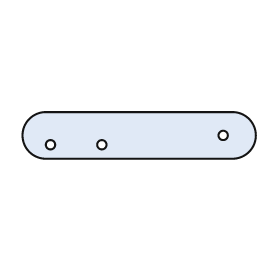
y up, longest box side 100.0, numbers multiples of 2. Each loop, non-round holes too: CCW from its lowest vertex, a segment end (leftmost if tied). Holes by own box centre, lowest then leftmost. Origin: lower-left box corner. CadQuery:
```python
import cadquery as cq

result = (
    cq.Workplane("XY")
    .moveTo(10.0, 0.0)
    .lineTo(90.0, 0.0)
    .threePointArc((100.0, 10.0), (90.0, 20.0))
    .lineTo(10.0, 20.0)
    .threePointArc((0.0, 10.0), (10.0, 0.0))
    .close()
    .moveTo(12.0, 6.0)
    .circle(2.0)
    .moveTo(34.0, 6.0)
    .circle(2.0)
    .moveTo(86.0, 10.0)
    .circle(2.0)
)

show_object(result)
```